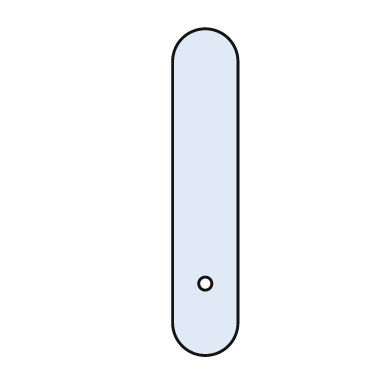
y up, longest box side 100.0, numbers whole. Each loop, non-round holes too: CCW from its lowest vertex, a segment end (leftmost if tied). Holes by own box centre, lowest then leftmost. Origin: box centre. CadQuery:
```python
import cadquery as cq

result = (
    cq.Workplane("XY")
    .moveTo(-10.0, -40.0)
    .threePointArc((0.0, -50.0), (10.0, -40.0))
    .lineTo(10.0, 40.0)
    .threePointArc((0.0, 50.0), (-10.0, 40.0))
    .close()
    .moveTo(0.0, -28.0)
    .circle(2.0)
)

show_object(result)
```